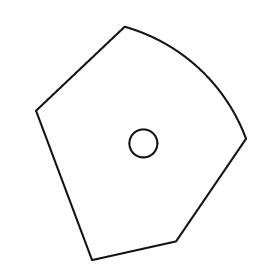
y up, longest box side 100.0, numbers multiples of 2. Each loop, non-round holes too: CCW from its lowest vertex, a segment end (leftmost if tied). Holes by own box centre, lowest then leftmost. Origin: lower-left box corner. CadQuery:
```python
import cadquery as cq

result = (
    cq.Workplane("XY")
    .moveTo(24.0, 0.0)
    .lineTo(60.0, 8.0)
    .lineTo(90.0, 52.0)
    .threePointArc((70.0, 82.0), (38.0, 100.0))
    .lineTo(0.0, 64.0)
    .close()
    .moveTo(46.0, 50.0)
    .circle(6.0)
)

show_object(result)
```